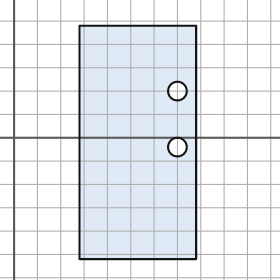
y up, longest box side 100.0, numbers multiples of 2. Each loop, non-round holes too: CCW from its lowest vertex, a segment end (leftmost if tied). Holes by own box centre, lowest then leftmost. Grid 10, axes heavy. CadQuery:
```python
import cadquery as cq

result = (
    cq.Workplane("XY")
    .moveTo(28.0, -52.0)
    .lineTo(78.0, -52.0)
    .lineTo(78.0, 48.0)
    .lineTo(28.0, 48.0)
    .close()
    .moveTo(70.0, -4.0)
    .circle(4.0)
    .moveTo(70.0, 20.0)
    .circle(4.0)
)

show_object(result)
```